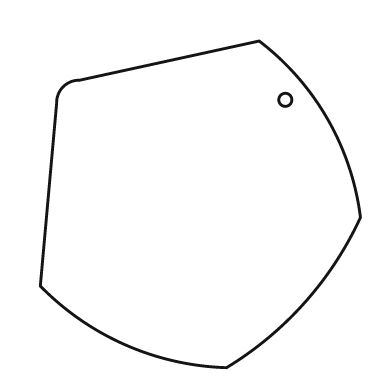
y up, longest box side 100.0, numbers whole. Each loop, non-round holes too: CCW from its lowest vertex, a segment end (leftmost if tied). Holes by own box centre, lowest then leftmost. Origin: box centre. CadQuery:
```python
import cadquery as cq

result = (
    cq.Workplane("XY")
    .moveTo(8.0, -50.0)
    .threePointArc((32.0, -30.0), (49.0, -4.0))
    .threePointArc((39.0, 26.0), (18.0, 50.0))
    .lineTo(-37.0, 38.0)
    .threePointArc((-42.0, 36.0), (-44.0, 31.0))
    .lineTo(-49.0, -25.0)
    .threePointArc((-23.0, -43.0), (8.0, -50.0))
    .close()
    .moveTo(26.0, 32.0)
    .circle(2.0)
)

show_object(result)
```